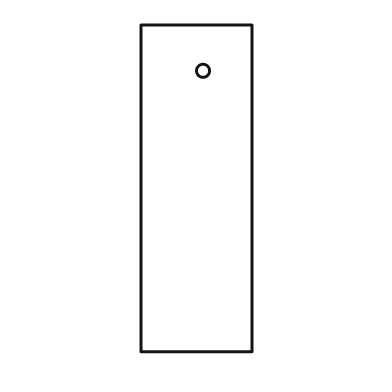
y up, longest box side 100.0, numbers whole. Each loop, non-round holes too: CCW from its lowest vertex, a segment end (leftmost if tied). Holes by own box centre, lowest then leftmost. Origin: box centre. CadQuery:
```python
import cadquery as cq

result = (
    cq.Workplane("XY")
    .moveTo(-17.0, -50.0)
    .lineTo(17.0, -50.0)
    .lineTo(17.0, 50.0)
    .lineTo(-17.0, 50.0)
    .close()
    .moveTo(2.0, 36.0)
    .circle(2.0)
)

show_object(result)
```